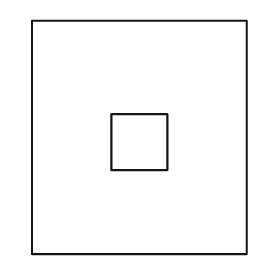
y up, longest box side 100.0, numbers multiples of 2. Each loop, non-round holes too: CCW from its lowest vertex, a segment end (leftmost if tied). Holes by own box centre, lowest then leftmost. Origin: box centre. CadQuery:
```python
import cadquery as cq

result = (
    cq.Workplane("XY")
    .moveTo(-46.0, -50.0)
    .lineTo(46.0, -50.0)
    .lineTo(46.0, 50.0)
    .lineTo(-46.0, 50.0)
    .close()
    .moveTo(-12.0, -14.0)
    .lineTo(12.0, -14.0)
    .lineTo(12.0, 10.0)
    .lineTo(-12.0, 10.0)
    .close()
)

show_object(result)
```